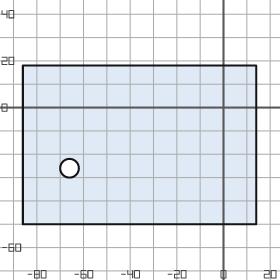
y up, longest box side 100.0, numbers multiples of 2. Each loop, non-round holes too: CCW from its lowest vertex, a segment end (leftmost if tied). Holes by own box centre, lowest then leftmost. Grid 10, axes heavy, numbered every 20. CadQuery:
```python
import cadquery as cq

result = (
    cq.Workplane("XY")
    .moveTo(-86.0, -50.0)
    .lineTo(14.0, -50.0)
    .lineTo(14.0, 18.0)
    .lineTo(-86.0, 18.0)
    .close()
    .moveTo(-66.0, -26.0)
    .circle(4.0)
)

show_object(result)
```